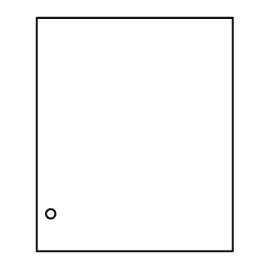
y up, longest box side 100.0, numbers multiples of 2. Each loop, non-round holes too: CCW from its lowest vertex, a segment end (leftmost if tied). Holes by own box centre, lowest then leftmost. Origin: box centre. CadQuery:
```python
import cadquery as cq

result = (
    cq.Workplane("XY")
    .moveTo(-42.0, -50.0)
    .lineTo(42.0, -50.0)
    .lineTo(42.0, 50.0)
    .lineTo(-42.0, 50.0)
    .close()
    .moveTo(-36.0, -34.0)
    .circle(2.0)
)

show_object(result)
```